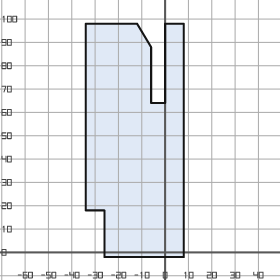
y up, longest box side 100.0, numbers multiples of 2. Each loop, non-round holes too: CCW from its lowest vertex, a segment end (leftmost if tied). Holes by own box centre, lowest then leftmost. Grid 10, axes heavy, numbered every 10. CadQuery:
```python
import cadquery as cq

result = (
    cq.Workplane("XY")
    .moveTo(-26.0, -2.0)
    .lineTo(8.0, -2.0)
    .lineTo(8.0, 98.0)
    .lineTo(0.0, 98.0)
    .lineTo(0.0, 64.0)
    .lineTo(-6.0, 64.0)
    .lineTo(-6.0, 88.0)
    .lineTo(-12.0, 98.0)
    .lineTo(-34.0, 98.0)
    .lineTo(-34.0, 18.0)
    .lineTo(-26.0, 18.0)
    .close()
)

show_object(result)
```